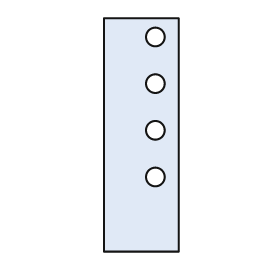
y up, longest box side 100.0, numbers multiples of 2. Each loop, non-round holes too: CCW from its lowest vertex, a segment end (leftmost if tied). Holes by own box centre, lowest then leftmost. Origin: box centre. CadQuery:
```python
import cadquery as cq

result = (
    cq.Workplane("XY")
    .moveTo(-16.0, -50.0)
    .lineTo(16.0, -50.0)
    .lineTo(16.0, 50.0)
    .lineTo(-16.0, 50.0)
    .close()
    .moveTo(6.0, -18.0)
    .circle(4.0)
    .moveTo(6.0, 2.0)
    .circle(4.0)
    .moveTo(6.0, 22.0)
    .circle(4.0)
    .moveTo(6.0, 42.0)
    .circle(4.0)
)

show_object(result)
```